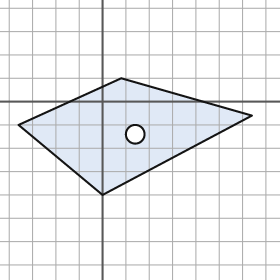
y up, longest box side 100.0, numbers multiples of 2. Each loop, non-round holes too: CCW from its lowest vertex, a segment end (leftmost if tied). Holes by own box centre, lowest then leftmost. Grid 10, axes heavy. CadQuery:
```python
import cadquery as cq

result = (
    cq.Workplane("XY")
    .moveTo(0.0, -40.0)
    .lineTo(64.0, -6.0)
    .lineTo(8.0, 10.0)
    .lineTo(-36.0, -10.0)
    .close()
    .moveTo(14.0, -14.0)
    .circle(4.0)
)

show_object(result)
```